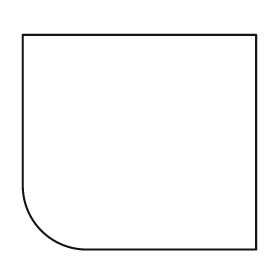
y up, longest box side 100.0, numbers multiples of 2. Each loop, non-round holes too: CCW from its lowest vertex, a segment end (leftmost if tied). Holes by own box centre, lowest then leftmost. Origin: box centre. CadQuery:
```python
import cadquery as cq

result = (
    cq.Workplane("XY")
    .moveTo(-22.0, -46.0)
    .lineTo(50.0, -46.0)
    .lineTo(50.0, 46.0)
    .lineTo(-50.0, 46.0)
    .lineTo(-50.0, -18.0)
    .threePointArc((-42.0, -38.0), (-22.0, -46.0))
    .close()
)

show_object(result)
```